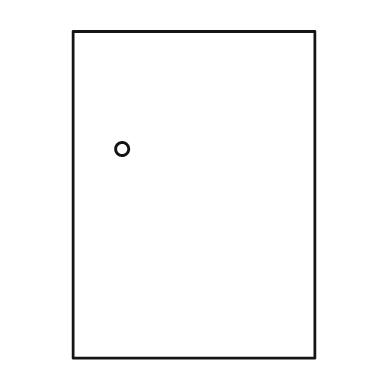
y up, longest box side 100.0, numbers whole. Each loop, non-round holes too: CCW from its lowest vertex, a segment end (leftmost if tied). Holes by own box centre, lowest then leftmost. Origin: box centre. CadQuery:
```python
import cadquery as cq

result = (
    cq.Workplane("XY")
    .moveTo(-37.0, -50.0)
    .lineTo(37.0, -50.0)
    .lineTo(37.0, 50.0)
    .lineTo(-37.0, 50.0)
    .close()
    .moveTo(-22.0, 14.0)
    .circle(2.0)
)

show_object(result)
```